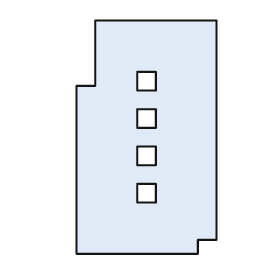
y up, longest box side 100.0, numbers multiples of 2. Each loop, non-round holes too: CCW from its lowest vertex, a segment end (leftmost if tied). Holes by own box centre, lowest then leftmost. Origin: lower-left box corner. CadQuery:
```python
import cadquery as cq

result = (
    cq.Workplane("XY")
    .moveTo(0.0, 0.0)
    .lineTo(52.0, 0.0)
    .lineTo(52.0, 6.0)
    .lineTo(60.0, 6.0)
    .lineTo(60.0, 100.0)
    .lineTo(8.0, 100.0)
    .lineTo(8.0, 72.0)
    .lineTo(0.0, 72.0)
    .close()
    .moveTo(26.0, 22.0)
    .lineTo(34.0, 22.0)
    .lineTo(34.0, 30.0)
    .lineTo(26.0, 30.0)
    .close()
    .moveTo(26.0, 38.0)
    .lineTo(34.0, 38.0)
    .lineTo(34.0, 46.0)
    .lineTo(26.0, 46.0)
    .close()
    .moveTo(26.0, 54.0)
    .lineTo(34.0, 54.0)
    .lineTo(34.0, 62.0)
    .lineTo(26.0, 62.0)
    .close()
    .moveTo(26.0, 70.0)
    .lineTo(34.0, 70.0)
    .lineTo(34.0, 78.0)
    .lineTo(26.0, 78.0)
    .close()
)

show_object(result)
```